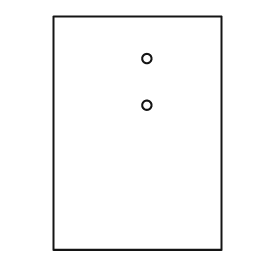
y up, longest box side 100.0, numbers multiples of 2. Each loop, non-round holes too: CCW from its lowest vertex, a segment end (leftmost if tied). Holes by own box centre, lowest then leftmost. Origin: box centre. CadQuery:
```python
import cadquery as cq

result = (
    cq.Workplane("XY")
    .moveTo(-36.0, -50.0)
    .lineTo(36.0, -50.0)
    .lineTo(36.0, 50.0)
    .lineTo(-36.0, 50.0)
    .close()
    .moveTo(4.0, 12.0)
    .circle(2.0)
    .moveTo(4.0, 32.0)
    .circle(2.0)
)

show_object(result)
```